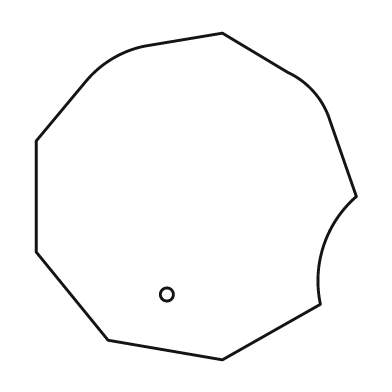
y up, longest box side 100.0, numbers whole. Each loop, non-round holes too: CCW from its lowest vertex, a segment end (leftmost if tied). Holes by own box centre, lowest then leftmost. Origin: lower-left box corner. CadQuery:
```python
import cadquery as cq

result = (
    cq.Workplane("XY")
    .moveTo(57.0, 0.0)
    .lineTo(87.0, 17.0)
    .threePointArc((88.0, 35.0), (98.0, 50.0))
    .lineTo(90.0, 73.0)
    .threePointArc((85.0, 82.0), (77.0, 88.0))
    .lineTo(57.0, 100.0)
    .lineTo(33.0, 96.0)
    .threePointArc((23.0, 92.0), (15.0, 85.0))
    .lineTo(0.0, 67.0)
    .lineTo(0.0, 33.0)
    .lineTo(22.0, 6.0)
    .close()
    .moveTo(40.0, 20.0)
    .circle(2.0)
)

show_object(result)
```